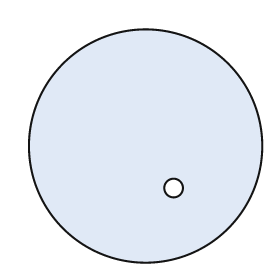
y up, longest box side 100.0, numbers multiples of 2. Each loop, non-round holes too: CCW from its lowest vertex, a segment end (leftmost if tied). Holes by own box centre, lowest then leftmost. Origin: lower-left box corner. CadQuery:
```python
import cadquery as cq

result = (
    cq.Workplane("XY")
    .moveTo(50.0, 50.0)
    .circle(50.0)
    .moveTo(62.0, 32.0)
    .circle(4.0)
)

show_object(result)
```